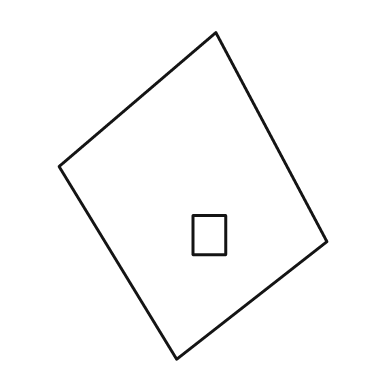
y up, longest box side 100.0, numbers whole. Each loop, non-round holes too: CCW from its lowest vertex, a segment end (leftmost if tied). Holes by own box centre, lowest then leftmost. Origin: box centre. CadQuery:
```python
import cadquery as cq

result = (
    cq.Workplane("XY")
    .moveTo(-5.0, -50.0)
    .lineTo(41.0, -14.0)
    .lineTo(7.0, 50.0)
    .lineTo(-41.0, 9.0)
    .close()
    .moveTo(0.0, -18.0)
    .lineTo(10.0, -18.0)
    .lineTo(10.0, -6.0)
    .lineTo(0.0, -6.0)
    .close()
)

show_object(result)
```